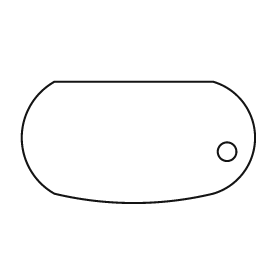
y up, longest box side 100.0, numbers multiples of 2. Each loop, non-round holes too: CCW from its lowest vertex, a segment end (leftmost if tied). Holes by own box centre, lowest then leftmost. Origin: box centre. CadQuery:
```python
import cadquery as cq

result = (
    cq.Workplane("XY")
    .moveTo(-36.0, -22.0)
    .threePointArc((-2.0, -26.0), (32.0, -22.0))
    .threePointArc((50.0, 2.0), (32.0, 26.0))
    .lineTo(-36.0, 26.0)
    .threePointArc((-50.0, 2.0), (-36.0, -22.0))
    .close()
    .moveTo(38.0, -4.0)
    .circle(4.0)
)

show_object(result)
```